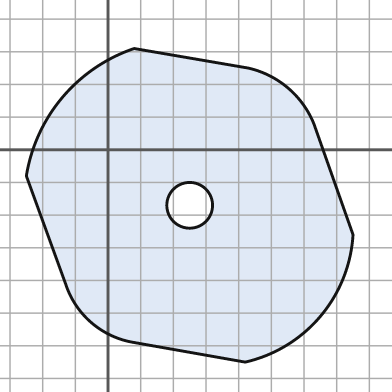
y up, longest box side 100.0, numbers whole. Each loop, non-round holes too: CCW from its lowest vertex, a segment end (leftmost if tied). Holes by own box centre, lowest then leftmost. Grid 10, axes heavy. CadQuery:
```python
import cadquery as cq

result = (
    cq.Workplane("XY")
    .moveTo(42.0, -65.0)
    .threePointArc((65.0, -51.0), (75.0, -26.0))
    .lineTo(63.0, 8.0)
    .threePointArc((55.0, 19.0), (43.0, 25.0))
    .lineTo(8.0, 31.0)
    .threePointArc((-14.0, 16.0), (-25.0, -8.0))
    .lineTo(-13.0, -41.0)
    .threePointArc((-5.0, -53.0), (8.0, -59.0))
    .close()
    .moveTo(25.0, -17.0)
    .circle(7.0)
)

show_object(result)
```